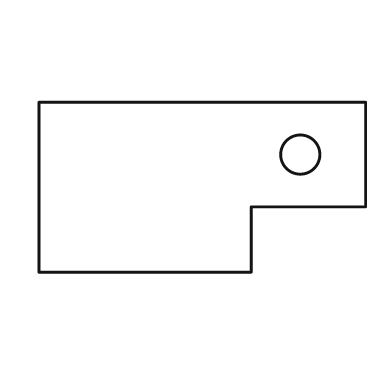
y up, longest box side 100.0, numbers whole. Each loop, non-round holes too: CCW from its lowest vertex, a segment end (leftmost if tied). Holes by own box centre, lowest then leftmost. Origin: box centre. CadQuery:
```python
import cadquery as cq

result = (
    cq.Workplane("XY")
    .moveTo(-50.0, -26.0)
    .lineTo(15.0, -26.0)
    .lineTo(15.0, -6.0)
    .lineTo(50.0, -6.0)
    .lineTo(50.0, 26.0)
    .lineTo(-50.0, 26.0)
    .close()
    .moveTo(30.0, 10.0)
    .circle(6.0)
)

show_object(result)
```